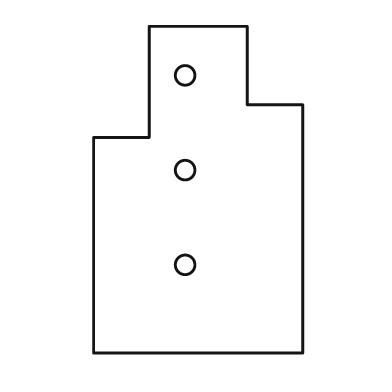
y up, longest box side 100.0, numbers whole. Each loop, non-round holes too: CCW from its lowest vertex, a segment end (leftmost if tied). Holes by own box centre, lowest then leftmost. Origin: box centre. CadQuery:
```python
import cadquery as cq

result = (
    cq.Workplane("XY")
    .moveTo(-32.0, -50.0)
    .lineTo(32.0, -50.0)
    .lineTo(32.0, 26.0)
    .lineTo(15.0, 26.0)
    .lineTo(15.0, 50.0)
    .lineTo(-15.0, 50.0)
    .lineTo(-15.0, 16.0)
    .lineTo(-32.0, 16.0)
    .close()
    .moveTo(-4.0, -23.0)
    .circle(3.0)
    .moveTo(-4.0, 6.0)
    .circle(3.0)
    .moveTo(-4.0, 35.0)
    .circle(3.0)
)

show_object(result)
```